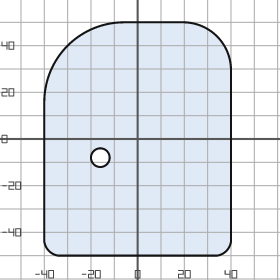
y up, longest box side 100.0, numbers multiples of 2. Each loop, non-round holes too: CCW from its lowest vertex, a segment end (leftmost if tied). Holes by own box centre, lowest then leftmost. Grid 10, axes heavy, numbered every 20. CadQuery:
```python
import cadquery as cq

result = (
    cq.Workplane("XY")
    .moveTo(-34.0, -50.0)
    .lineTo(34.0, -50.0)
    .threePointArc((38.0, -48.0), (40.0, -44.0))
    .lineTo(40.0, 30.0)
    .threePointArc((34.0, 44.0), (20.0, 50.0))
    .lineTo(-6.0, 50.0)
    .threePointArc((-30.0, 40.0), (-40.0, 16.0))
    .lineTo(-40.0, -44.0)
    .threePointArc((-38.0, -48.0), (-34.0, -50.0))
    .close()
    .moveTo(-16.0, -8.0)
    .circle(4.0)
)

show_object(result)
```